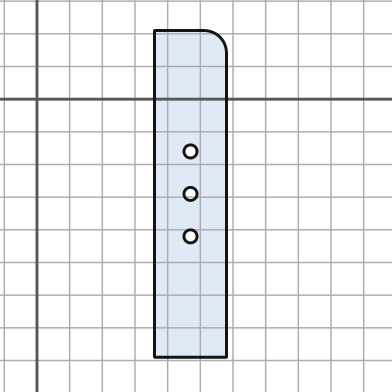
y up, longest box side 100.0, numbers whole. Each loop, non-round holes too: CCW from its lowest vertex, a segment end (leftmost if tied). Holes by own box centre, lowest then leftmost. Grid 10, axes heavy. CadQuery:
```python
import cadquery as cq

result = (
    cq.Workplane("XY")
    .moveTo(36.0, -79.0)
    .lineTo(58.0, -79.0)
    .lineTo(58.0, 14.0)
    .threePointArc((56.0, 19.0), (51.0, 21.0))
    .lineTo(36.0, 21.0)
    .close()
    .moveTo(47.0, -42.0)
    .circle(2.0)
    .moveTo(47.0, -29.0)
    .circle(2.0)
    .moveTo(47.0, -16.0)
    .circle(2.0)
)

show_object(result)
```